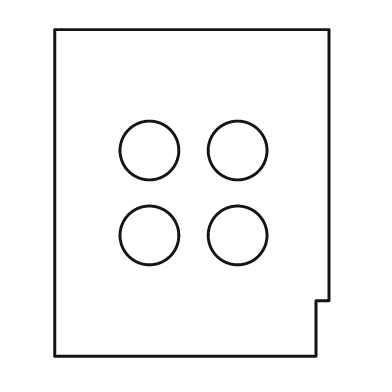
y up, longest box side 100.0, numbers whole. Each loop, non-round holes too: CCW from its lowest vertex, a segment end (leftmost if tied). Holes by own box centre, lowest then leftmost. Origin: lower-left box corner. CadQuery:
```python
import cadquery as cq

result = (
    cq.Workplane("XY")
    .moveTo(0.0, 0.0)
    .lineTo(80.0, 0.0)
    .lineTo(80.0, 17.0)
    .lineTo(84.0, 17.0)
    .lineTo(84.0, 100.0)
    .lineTo(0.0, 100.0)
    .close()
    .moveTo(29.0, 37.0)
    .circle(9.0)
    .moveTo(56.0, 37.0)
    .circle(9.0)
    .moveTo(29.0, 63.0)
    .circle(9.0)
    .moveTo(56.0, 63.0)
    .circle(9.0)
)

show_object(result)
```